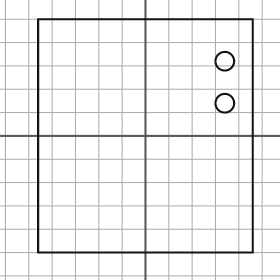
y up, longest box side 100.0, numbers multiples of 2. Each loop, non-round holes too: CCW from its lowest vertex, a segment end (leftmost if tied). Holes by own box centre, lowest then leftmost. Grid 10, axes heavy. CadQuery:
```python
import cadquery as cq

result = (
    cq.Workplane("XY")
    .moveTo(-46.0, -50.0)
    .lineTo(46.0, -50.0)
    .lineTo(46.0, 50.0)
    .lineTo(-46.0, 50.0)
    .close()
    .moveTo(34.0, 14.0)
    .circle(4.0)
    .moveTo(34.0, 32.0)
    .circle(4.0)
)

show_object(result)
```